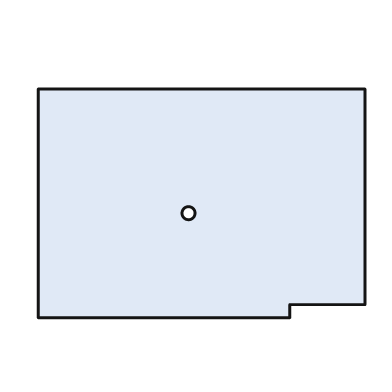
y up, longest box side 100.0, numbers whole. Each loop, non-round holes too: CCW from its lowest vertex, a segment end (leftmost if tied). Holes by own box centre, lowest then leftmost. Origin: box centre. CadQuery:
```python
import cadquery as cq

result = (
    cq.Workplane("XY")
    .moveTo(-50.0, -35.0)
    .lineTo(27.0, -35.0)
    .lineTo(27.0, -31.0)
    .lineTo(50.0, -31.0)
    .lineTo(50.0, 35.0)
    .lineTo(-50.0, 35.0)
    .close()
    .moveTo(-4.0, -3.0)
    .circle(2.0)
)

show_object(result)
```